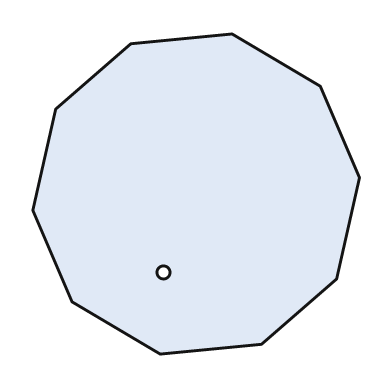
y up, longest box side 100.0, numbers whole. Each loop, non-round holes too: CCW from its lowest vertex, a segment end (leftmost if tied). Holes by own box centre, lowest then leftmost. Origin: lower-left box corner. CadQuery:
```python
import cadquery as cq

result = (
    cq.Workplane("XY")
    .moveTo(39.0, 0.0)
    .lineTo(70.0, 3.0)
    .lineTo(93.0, 23.0)
    .lineTo(100.0, 54.0)
    .lineTo(88.0, 82.0)
    .lineTo(61.0, 98.0)
    .lineTo(30.0, 95.0)
    .lineTo(7.0, 75.0)
    .lineTo(0.0, 44.0)
    .lineTo(12.0, 16.0)
    .close()
    .moveTo(40.0, 25.0)
    .circle(2.0)
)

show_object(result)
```